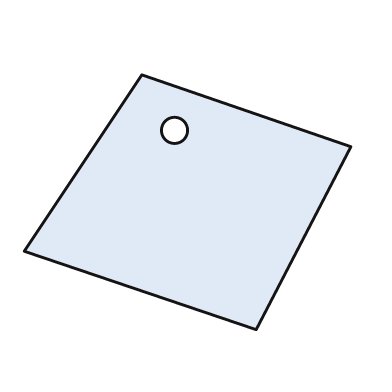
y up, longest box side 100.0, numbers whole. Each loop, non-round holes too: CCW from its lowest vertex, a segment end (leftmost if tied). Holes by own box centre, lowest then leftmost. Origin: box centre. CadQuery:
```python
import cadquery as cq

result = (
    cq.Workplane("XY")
    .moveTo(21.0, -39.0)
    .lineTo(50.0, 17.0)
    .lineTo(-14.0, 39.0)
    .lineTo(-50.0, -15.0)
    .close()
    .moveTo(-4.0, 22.0)
    .circle(4.0)
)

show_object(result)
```